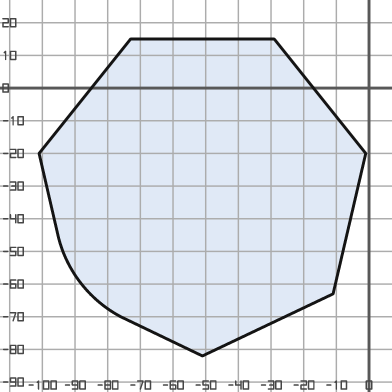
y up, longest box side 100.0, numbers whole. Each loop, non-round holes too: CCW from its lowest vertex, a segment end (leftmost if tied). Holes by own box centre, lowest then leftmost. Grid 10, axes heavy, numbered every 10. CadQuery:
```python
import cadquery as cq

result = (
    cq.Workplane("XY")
    .moveTo(-51.0, -82.0)
    .lineTo(-11.0, -63.0)
    .lineTo(-1.0, -20.0)
    .lineTo(-29.0, 15.0)
    .lineTo(-73.0, 15.0)
    .lineTo(-101.0, -20.0)
    .lineTo(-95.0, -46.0)
    .threePointArc((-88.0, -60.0), (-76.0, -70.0))
    .close()
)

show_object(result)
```